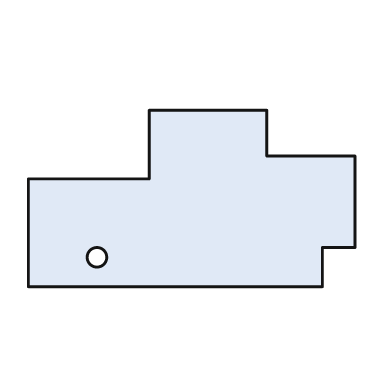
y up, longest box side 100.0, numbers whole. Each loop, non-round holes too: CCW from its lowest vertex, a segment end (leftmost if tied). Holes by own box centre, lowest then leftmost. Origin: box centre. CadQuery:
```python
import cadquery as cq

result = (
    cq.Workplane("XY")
    .moveTo(-50.0, -27.0)
    .lineTo(40.0, -27.0)
    .lineTo(40.0, -15.0)
    .lineTo(50.0, -15.0)
    .lineTo(50.0, 13.0)
    .lineTo(23.0, 13.0)
    .lineTo(23.0, 27.0)
    .lineTo(-13.0, 27.0)
    .lineTo(-13.0, 6.0)
    .lineTo(-50.0, 6.0)
    .close()
    .moveTo(-29.0, -18.0)
    .circle(3.0)
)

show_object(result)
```